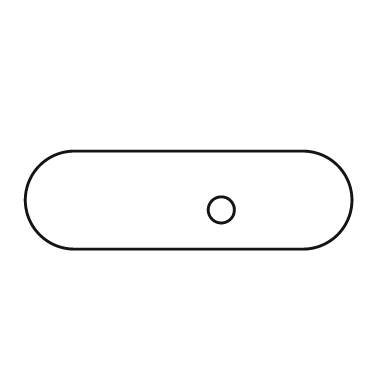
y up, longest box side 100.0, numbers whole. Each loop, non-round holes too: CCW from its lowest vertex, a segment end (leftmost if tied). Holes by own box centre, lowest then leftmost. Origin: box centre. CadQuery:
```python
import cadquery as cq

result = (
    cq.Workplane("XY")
    .moveTo(-35.0, -15.0)
    .lineTo(35.0, -15.0)
    .threePointArc((50.0, 0.0), (35.0, 15.0))
    .lineTo(-35.0, 15.0)
    .threePointArc((-50.0, 0.0), (-35.0, -15.0))
    .close()
    .moveTo(10.0, -3.0)
    .circle(4.0)
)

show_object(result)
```